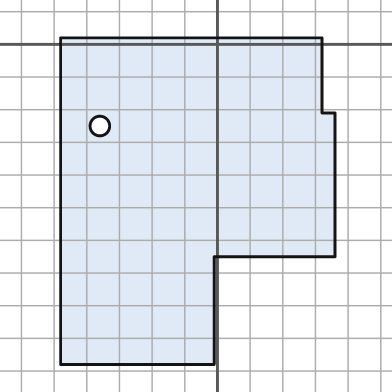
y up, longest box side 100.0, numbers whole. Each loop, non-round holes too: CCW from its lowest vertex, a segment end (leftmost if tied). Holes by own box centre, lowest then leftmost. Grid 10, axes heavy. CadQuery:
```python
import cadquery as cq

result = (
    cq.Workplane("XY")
    .moveTo(-48.0, -98.0)
    .lineTo(-1.0, -98.0)
    .lineTo(-1.0, -65.0)
    .lineTo(36.0, -65.0)
    .lineTo(36.0, -21.0)
    .lineTo(32.0, -21.0)
    .lineTo(32.0, 2.0)
    .lineTo(-48.0, 2.0)
    .close()
    .moveTo(-36.0, -25.0)
    .circle(3.0)
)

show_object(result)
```